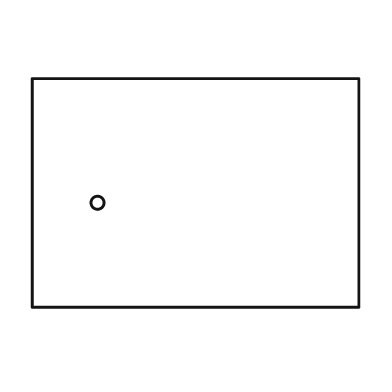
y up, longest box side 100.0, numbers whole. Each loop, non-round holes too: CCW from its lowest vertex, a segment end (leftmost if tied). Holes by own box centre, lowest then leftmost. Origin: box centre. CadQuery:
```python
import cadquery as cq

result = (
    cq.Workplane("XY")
    .moveTo(-50.0, -35.0)
    .lineTo(50.0, -35.0)
    .lineTo(50.0, 35.0)
    .lineTo(-50.0, 35.0)
    .close()
    .moveTo(-30.0, -3.0)
    .circle(2.0)
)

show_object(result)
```